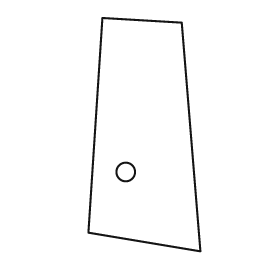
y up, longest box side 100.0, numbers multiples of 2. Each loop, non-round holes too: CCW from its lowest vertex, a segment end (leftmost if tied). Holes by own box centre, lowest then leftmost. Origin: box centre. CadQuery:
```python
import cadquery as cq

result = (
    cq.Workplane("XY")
    .moveTo(24.0, -50.0)
    .lineTo(16.0, 48.0)
    .lineTo(-18.0, 50.0)
    .lineTo(-24.0, -42.0)
    .close()
    .moveTo(-8.0, -16.0)
    .circle(4.0)
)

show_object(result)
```